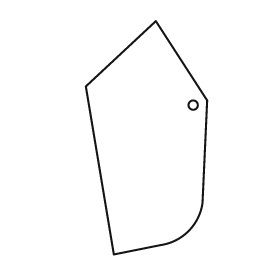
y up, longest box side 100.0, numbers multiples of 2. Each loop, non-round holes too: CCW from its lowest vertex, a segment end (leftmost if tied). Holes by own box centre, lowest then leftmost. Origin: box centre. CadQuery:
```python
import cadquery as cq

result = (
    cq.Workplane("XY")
    .moveTo(-14.0, -50.0)
    .lineTo(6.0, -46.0)
    .threePointArc((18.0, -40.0), (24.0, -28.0))
    .lineTo(26.0, 16.0)
    .lineTo(4.0, 50.0)
    .lineTo(-26.0, 22.0)
    .close()
    .moveTo(20.0, 14.0)
    .circle(2.0)
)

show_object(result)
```